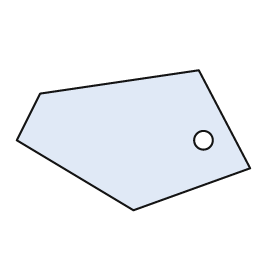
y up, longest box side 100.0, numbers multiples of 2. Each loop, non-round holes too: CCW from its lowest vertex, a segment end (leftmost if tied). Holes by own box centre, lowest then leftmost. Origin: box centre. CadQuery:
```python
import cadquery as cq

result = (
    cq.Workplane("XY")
    .moveTo(0.0, -30.0)
    .lineTo(50.0, -12.0)
    .lineTo(28.0, 30.0)
    .lineTo(-40.0, 20.0)
    .lineTo(-50.0, 0.0)
    .close()
    .moveTo(30.0, 0.0)
    .circle(4.0)
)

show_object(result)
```